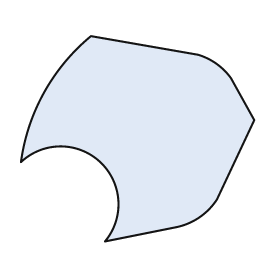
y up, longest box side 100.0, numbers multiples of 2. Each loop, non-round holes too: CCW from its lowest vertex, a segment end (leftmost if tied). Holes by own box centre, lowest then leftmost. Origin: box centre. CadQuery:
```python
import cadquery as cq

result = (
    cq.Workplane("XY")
    .moveTo(-14.0, -44.0)
    .lineTo(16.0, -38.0)
    .threePointArc((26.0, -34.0), (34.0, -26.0))
    .lineTo(50.0, 8.0)
    .lineTo(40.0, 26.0)
    .threePointArc((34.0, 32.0), (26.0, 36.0))
    .lineTo(-20.0, 44.0)
    .threePointArc((-40.0, 20.0), (-50.0, -10.0))
    .threePointArc((-16.0, -10.0), (-14.0, -44.0))
    .close()
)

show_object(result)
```